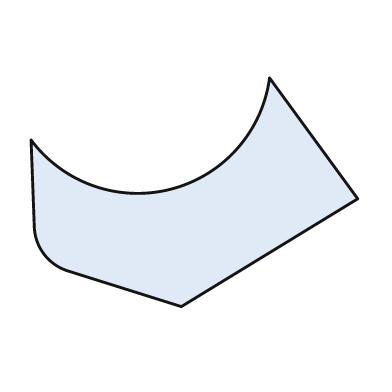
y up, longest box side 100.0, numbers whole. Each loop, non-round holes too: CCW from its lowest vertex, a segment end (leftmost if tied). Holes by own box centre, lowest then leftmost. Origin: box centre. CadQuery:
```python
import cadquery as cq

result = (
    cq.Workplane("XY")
    .moveTo(-4.0, -35.0)
    .lineTo(50.0, -2.0)
    .lineTo(23.0, 35.0)
    .threePointArc((-7.0, 1.0), (-50.0, 16.0))
    .lineTo(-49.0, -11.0)
    .threePointArc((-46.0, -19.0), (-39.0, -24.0))
    .close()
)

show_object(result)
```